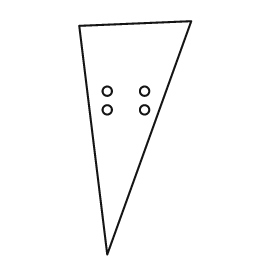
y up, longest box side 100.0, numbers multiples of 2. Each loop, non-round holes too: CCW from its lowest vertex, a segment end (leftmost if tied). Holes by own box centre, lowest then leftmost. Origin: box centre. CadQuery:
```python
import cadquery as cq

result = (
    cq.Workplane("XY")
    .moveTo(-12.0, -50.0)
    .lineTo(24.0, 50.0)
    .lineTo(-24.0, 48.0)
    .close()
    .moveTo(-12.0, 12.0)
    .circle(2.0)
    .moveTo(4.0, 12.0)
    .circle(2.0)
    .moveTo(-12.0, 20.0)
    .circle(2.0)
    .moveTo(4.0, 20.0)
    .circle(2.0)
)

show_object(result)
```